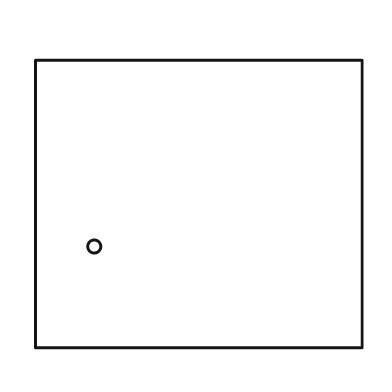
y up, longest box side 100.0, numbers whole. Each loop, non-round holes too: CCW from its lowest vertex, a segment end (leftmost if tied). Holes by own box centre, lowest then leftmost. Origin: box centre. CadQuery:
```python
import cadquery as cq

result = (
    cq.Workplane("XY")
    .moveTo(-50.0, -44.0)
    .lineTo(50.0, -44.0)
    .lineTo(50.0, 44.0)
    .lineTo(-50.0, 44.0)
    .close()
    .moveTo(-32.0, -13.0)
    .circle(2.0)
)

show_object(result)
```